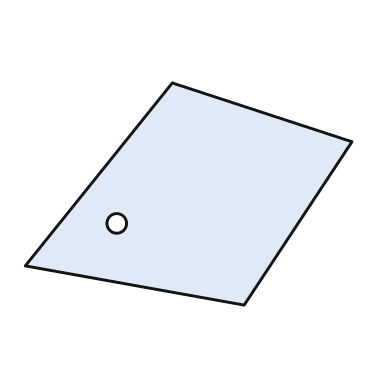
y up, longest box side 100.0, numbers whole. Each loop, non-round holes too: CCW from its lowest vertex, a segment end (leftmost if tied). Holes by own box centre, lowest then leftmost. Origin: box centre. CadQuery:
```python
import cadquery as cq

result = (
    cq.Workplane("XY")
    .moveTo(17.0, -34.0)
    .lineTo(50.0, 16.0)
    .lineTo(-5.0, 34.0)
    .lineTo(-50.0, -22.0)
    .close()
    .moveTo(-22.0, -9.0)
    .circle(3.0)
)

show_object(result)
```